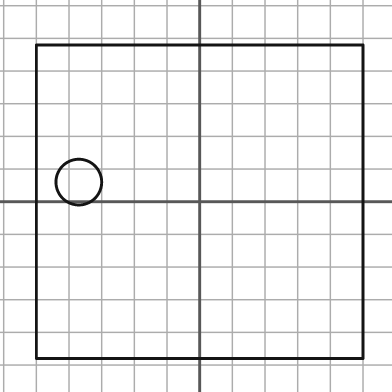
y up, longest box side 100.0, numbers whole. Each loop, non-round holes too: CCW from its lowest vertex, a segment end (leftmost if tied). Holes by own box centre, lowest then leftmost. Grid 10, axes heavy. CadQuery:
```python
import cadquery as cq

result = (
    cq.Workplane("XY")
    .moveTo(-50.0, -48.0)
    .lineTo(50.0, -48.0)
    .lineTo(50.0, 48.0)
    .lineTo(-50.0, 48.0)
    .close()
    .moveTo(-37.0, 6.0)
    .circle(7.0)
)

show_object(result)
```